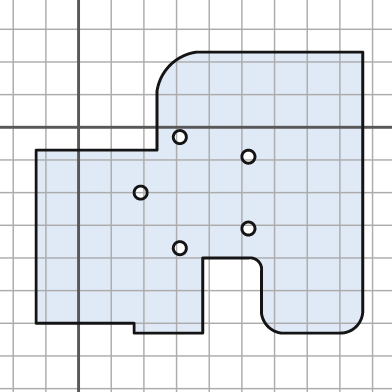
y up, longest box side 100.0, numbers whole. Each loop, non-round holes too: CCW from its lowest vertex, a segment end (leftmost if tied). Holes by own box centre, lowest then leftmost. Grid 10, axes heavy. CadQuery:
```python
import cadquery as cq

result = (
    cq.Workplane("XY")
    .moveTo(17.0, -63.0)
    .lineTo(38.0, -63.0)
    .lineTo(38.0, -40.0)
    .lineTo(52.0, -40.0)
    .threePointArc((55.0, -41.0), (56.0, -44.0))
    .lineTo(56.0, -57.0)
    .threePointArc((58.0, -61.0), (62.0, -63.0))
    .lineTo(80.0, -63.0)
    .threePointArc((85.0, -61.0), (87.0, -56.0))
    .lineTo(87.0, 23.0)
    .lineTo(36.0, 23.0)
    .threePointArc((28.0, 19.0), (24.0, 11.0))
    .lineTo(24.0, -7.0)
    .lineTo(-13.0, -7.0)
    .lineTo(-13.0, -60.0)
    .lineTo(17.0, -60.0)
    .close()
    .moveTo(31.0, -37.0)
    .circle(2.0)
    .moveTo(52.0, -31.0)
    .circle(2.0)
    .moveTo(19.0, -20.0)
    .circle(2.0)
    .moveTo(52.0, -9.0)
    .circle(2.0)
    .moveTo(31.0, -3.0)
    .circle(2.0)
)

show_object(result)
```